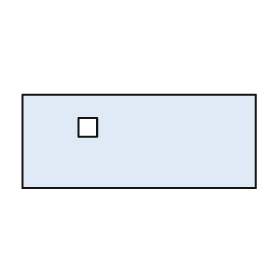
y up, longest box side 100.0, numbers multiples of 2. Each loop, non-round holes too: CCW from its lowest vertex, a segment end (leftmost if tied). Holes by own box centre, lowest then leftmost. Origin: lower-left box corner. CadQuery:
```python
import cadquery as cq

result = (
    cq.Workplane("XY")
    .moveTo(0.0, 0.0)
    .lineTo(100.0, 0.0)
    .lineTo(100.0, 40.0)
    .lineTo(0.0, 40.0)
    .close()
    .moveTo(24.0, 22.0)
    .lineTo(32.0, 22.0)
    .lineTo(32.0, 30.0)
    .lineTo(24.0, 30.0)
    .close()
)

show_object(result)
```